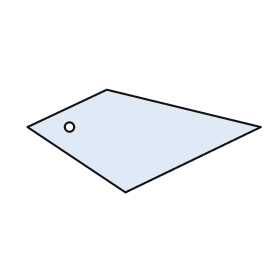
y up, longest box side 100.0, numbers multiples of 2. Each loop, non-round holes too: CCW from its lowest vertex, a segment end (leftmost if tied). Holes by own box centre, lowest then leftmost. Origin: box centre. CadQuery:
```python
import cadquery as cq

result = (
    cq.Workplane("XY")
    .moveTo(-8.0, -22.0)
    .lineTo(50.0, 6.0)
    .lineTo(-16.0, 22.0)
    .lineTo(-50.0, 6.0)
    .close()
    .moveTo(-32.0, 6.0)
    .circle(2.0)
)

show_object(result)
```